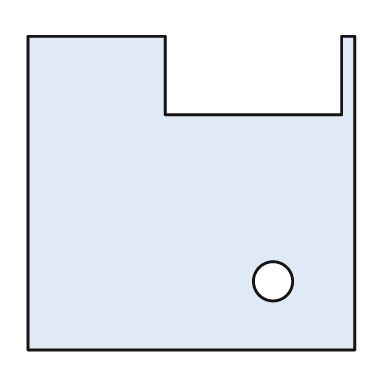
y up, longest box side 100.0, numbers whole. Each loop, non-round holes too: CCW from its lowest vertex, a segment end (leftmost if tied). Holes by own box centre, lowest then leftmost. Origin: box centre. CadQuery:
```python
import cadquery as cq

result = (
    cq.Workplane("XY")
    .moveTo(-50.0, -48.0)
    .lineTo(50.0, -48.0)
    .lineTo(50.0, 48.0)
    .lineTo(46.0, 48.0)
    .lineTo(46.0, 24.0)
    .lineTo(-8.0, 24.0)
    .lineTo(-8.0, 48.0)
    .lineTo(-50.0, 48.0)
    .close()
    .moveTo(25.0, -27.0)
    .circle(6.0)
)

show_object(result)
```